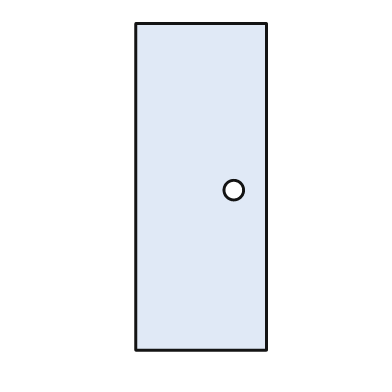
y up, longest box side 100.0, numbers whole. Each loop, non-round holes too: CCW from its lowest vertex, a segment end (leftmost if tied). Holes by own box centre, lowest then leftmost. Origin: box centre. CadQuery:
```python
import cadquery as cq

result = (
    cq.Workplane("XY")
    .moveTo(-20.0, -50.0)
    .lineTo(20.0, -50.0)
    .lineTo(20.0, 50.0)
    .lineTo(-20.0, 50.0)
    .close()
    .moveTo(10.0, -1.0)
    .circle(3.0)
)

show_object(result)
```